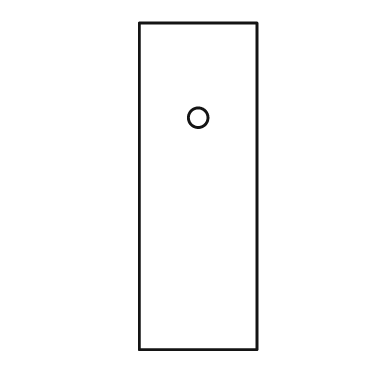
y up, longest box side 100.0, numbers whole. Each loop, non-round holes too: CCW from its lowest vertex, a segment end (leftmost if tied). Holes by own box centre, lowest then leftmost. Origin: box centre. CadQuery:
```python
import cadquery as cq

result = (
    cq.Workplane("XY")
    .moveTo(-18.0, -50.0)
    .lineTo(18.0, -50.0)
    .lineTo(18.0, 50.0)
    .lineTo(-18.0, 50.0)
    .close()
    .moveTo(0.0, 21.0)
    .circle(3.0)
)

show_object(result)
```